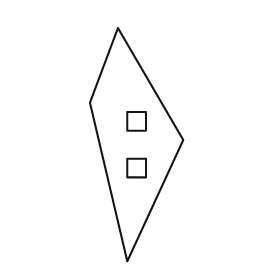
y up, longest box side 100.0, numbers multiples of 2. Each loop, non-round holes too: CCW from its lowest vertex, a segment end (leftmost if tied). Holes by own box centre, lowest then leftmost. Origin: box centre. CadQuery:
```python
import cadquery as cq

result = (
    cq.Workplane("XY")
    .moveTo(-4.0, -50.0)
    .lineTo(20.0, 2.0)
    .lineTo(-8.0, 50.0)
    .lineTo(-20.0, 18.0)
    .close()
    .moveTo(-4.0, -14.0)
    .lineTo(4.0, -14.0)
    .lineTo(4.0, -6.0)
    .lineTo(-4.0, -6.0)
    .close()
    .moveTo(-4.0, 6.0)
    .lineTo(4.0, 6.0)
    .lineTo(4.0, 14.0)
    .lineTo(-4.0, 14.0)
    .close()
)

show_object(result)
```